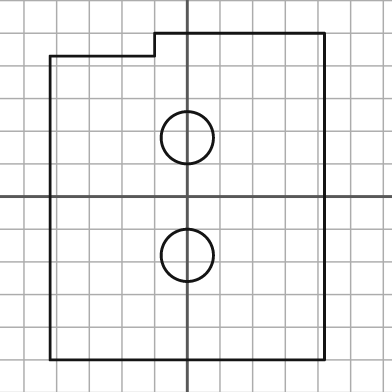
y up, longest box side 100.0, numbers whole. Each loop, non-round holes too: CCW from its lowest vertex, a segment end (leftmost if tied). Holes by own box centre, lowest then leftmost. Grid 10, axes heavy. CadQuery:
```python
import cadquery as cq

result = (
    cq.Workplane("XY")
    .moveTo(-42.0, -50.0)
    .lineTo(42.0, -50.0)
    .lineTo(42.0, 50.0)
    .lineTo(-10.0, 50.0)
    .lineTo(-10.0, 43.0)
    .lineTo(-42.0, 43.0)
    .close()
    .moveTo(0.0, -18.0)
    .circle(8.0)
    .moveTo(0.0, 18.0)
    .circle(8.0)
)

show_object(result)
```